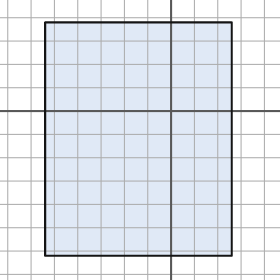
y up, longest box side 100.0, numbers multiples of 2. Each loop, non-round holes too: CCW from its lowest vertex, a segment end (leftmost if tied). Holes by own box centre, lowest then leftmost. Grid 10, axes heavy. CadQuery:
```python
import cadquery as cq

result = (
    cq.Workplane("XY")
    .moveTo(-54.0, -62.0)
    .lineTo(26.0, -62.0)
    .lineTo(26.0, 38.0)
    .lineTo(-54.0, 38.0)
    .close()
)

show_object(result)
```